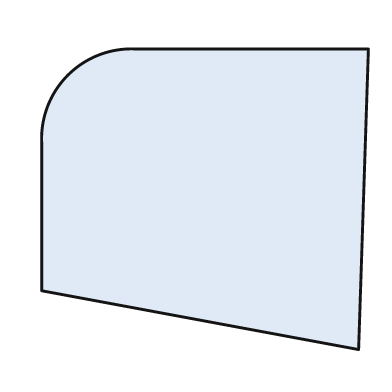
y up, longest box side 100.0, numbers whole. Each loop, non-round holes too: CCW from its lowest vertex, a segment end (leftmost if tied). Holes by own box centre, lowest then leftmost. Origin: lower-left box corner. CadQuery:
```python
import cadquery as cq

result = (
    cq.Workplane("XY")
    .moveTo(97.0, 0.0)
    .lineTo(100.0, 92.0)
    .lineTo(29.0, 92.0)
    .threePointArc((8.0, 84.0), (0.0, 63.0))
    .lineTo(0.0, 18.0)
    .close()
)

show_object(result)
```